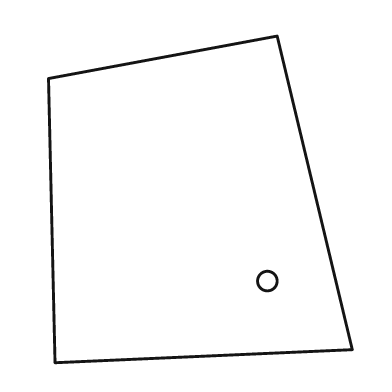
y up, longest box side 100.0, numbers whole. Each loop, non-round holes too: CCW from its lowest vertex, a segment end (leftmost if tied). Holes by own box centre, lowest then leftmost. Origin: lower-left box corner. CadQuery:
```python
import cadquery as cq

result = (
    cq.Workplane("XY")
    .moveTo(2.0, 0.0)
    .lineTo(93.0, 4.0)
    .lineTo(70.0, 100.0)
    .lineTo(0.0, 87.0)
    .close()
    .moveTo(67.0, 25.0)
    .circle(3.0)
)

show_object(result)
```